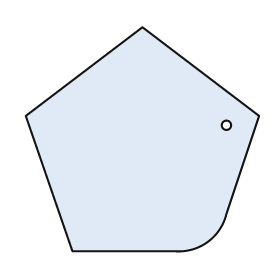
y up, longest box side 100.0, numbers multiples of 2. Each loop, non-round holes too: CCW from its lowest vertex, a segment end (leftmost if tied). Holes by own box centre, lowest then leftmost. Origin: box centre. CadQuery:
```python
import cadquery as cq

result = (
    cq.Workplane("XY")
    .moveTo(-30.0, -48.0)
    .lineTo(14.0, -48.0)
    .threePointArc((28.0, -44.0), (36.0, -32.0))
    .lineTo(50.0, 10.0)
    .lineTo(0.0, 48.0)
    .lineTo(-50.0, 10.0)
    .close()
    .moveTo(36.0, 6.0)
    .circle(2.0)
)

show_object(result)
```